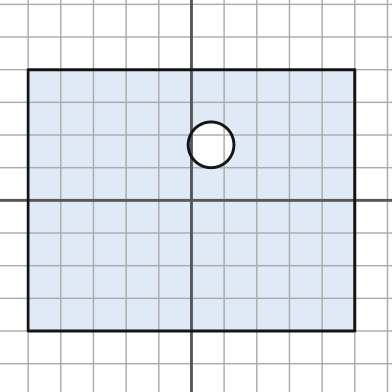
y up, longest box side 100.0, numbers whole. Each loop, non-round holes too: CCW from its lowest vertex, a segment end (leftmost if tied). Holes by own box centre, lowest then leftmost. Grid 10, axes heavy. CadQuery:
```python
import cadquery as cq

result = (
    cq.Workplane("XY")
    .moveTo(-50.0, -40.0)
    .lineTo(50.0, -40.0)
    .lineTo(50.0, 40.0)
    .lineTo(-50.0, 40.0)
    .close()
    .moveTo(6.0, 17.0)
    .circle(7.0)
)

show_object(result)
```